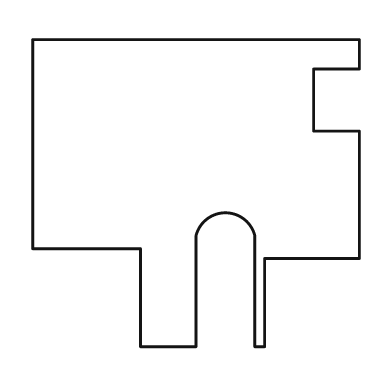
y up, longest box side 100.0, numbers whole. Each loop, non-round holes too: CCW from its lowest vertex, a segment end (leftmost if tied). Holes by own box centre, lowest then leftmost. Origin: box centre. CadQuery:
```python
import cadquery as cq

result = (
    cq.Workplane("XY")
    .moveTo(-17.0, -47.0)
    .lineTo(0.0, -47.0)
    .lineTo(0.0, -13.0)
    .threePointArc((9.0, -6.0), (18.0, -13.0))
    .lineTo(18.0, -47.0)
    .lineTo(21.0, -47.0)
    .lineTo(21.0, -20.0)
    .lineTo(50.0, -20.0)
    .lineTo(50.0, 19.0)
    .lineTo(36.0, 19.0)
    .lineTo(36.0, 38.0)
    .lineTo(50.0, 38.0)
    .lineTo(50.0, 47.0)
    .lineTo(-50.0, 47.0)
    .lineTo(-50.0, -17.0)
    .lineTo(-17.0, -17.0)
    .close()
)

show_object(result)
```